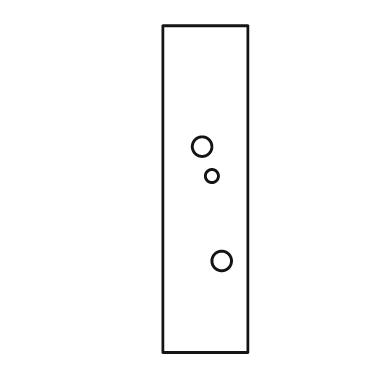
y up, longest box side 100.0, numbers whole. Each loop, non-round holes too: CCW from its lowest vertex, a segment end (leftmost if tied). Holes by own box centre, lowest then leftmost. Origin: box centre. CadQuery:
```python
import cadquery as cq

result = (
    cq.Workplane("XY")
    .moveTo(-13.0, -50.0)
    .lineTo(13.0, -50.0)
    .lineTo(13.0, 50.0)
    .lineTo(-13.0, 50.0)
    .close()
    .moveTo(5.0, -22.0)
    .circle(3.0)
    .moveTo(2.0, 4.0)
    .circle(2.0)
    .moveTo(-1.0, 13.0)
    .circle(3.0)
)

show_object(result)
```